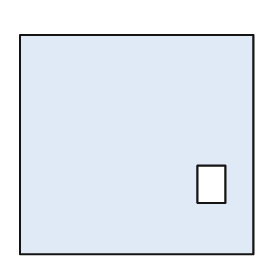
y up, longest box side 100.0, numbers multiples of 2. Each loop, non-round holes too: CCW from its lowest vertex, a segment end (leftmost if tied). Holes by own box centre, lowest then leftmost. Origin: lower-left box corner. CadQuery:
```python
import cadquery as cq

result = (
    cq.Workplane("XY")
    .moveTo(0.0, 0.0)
    .lineTo(100.0, 0.0)
    .lineTo(100.0, 94.0)
    .lineTo(0.0, 94.0)
    .close()
    .moveTo(76.0, 22.0)
    .lineTo(88.0, 22.0)
    .lineTo(88.0, 38.0)
    .lineTo(76.0, 38.0)
    .close()
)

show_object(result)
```